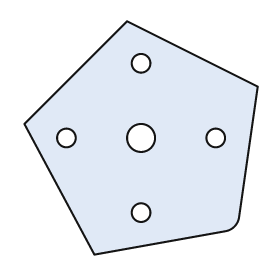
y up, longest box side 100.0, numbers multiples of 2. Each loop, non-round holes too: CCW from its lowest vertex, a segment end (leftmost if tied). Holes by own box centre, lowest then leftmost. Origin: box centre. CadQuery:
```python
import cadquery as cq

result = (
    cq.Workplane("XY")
    .moveTo(-20.0, -50.0)
    .lineTo(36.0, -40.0)
    .threePointArc((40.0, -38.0), (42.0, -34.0))
    .lineTo(50.0, 22.0)
    .lineTo(-6.0, 50.0)
    .lineTo(-50.0, 6.0)
    .close()
    .moveTo(0.0, -32.0)
    .circle(4.0)
    .moveTo(-32.0, 0.0)
    .circle(4.0)
    .moveTo(0.0, 0.0)
    .circle(6.0)
    .moveTo(32.0, 0.0)
    .circle(4.0)
    .moveTo(0.0, 32.0)
    .circle(4.0)
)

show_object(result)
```